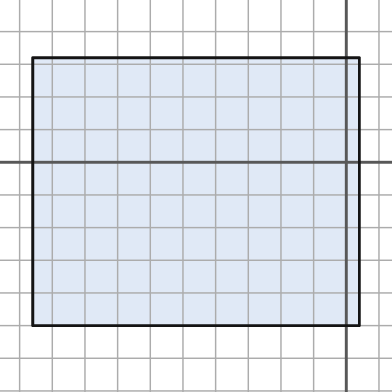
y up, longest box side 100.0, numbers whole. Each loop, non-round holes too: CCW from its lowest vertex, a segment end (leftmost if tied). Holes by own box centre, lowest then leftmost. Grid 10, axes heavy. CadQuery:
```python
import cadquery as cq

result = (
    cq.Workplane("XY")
    .moveTo(-96.0, -50.0)
    .lineTo(4.0, -50.0)
    .lineTo(4.0, 32.0)
    .lineTo(-96.0, 32.0)
    .close()
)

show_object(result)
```